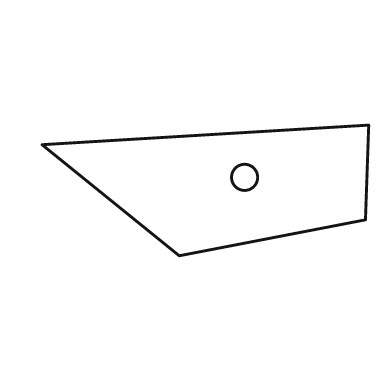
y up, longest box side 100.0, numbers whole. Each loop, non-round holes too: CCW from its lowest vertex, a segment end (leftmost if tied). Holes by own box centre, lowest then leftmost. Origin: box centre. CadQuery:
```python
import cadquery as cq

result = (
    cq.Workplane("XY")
    .moveTo(-8.0, -20.0)
    .lineTo(49.0, -9.0)
    .lineTo(50.0, 20.0)
    .lineTo(-50.0, 14.0)
    .close()
    .moveTo(12.0, 4.0)
    .circle(4.0)
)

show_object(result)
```